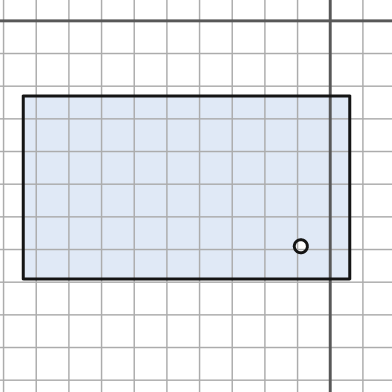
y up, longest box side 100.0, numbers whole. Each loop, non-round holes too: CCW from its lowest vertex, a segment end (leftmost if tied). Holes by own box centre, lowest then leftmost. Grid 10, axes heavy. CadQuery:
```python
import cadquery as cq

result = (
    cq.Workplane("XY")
    .moveTo(-94.0, -79.0)
    .lineTo(6.0, -79.0)
    .lineTo(6.0, -23.0)
    .lineTo(-94.0, -23.0)
    .close()
    .moveTo(-9.0, -69.0)
    .circle(2.0)
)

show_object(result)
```